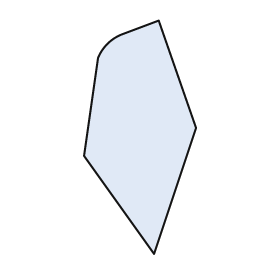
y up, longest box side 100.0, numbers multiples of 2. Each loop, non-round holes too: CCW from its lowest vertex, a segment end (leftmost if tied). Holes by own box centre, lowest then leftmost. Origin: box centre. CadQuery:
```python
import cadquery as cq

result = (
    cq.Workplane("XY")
    .moveTo(6.0, -50.0)
    .lineTo(24.0, 4.0)
    .lineTo(8.0, 50.0)
    .lineTo(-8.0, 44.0)
    .threePointArc((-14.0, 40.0), (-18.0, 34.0))
    .lineTo(-24.0, -8.0)
    .close()
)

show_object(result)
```